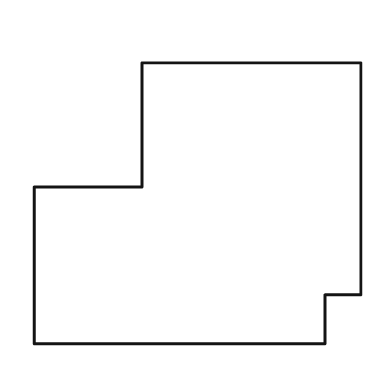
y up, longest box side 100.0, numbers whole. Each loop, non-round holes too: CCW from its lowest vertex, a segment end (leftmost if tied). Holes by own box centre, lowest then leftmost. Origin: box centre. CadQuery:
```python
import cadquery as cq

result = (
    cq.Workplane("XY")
    .moveTo(-50.0, -43.0)
    .lineTo(39.0, -43.0)
    .lineTo(39.0, -28.0)
    .lineTo(50.0, -28.0)
    .lineTo(50.0, 43.0)
    .lineTo(-17.0, 43.0)
    .lineTo(-17.0, 5.0)
    .lineTo(-50.0, 5.0)
    .close()
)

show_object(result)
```